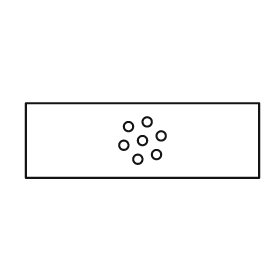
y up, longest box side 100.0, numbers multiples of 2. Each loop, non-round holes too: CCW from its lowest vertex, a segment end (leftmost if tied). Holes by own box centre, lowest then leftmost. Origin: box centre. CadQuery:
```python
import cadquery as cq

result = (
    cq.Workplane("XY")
    .moveTo(-50.0, -16.0)
    .lineTo(50.0, -16.0)
    .lineTo(50.0, 16.0)
    .lineTo(-50.0, 16.0)
    .close()
    .moveTo(-2.0, -8.0)
    .circle(2.0)
    .moveTo(6.0, -6.0)
    .circle(2.0)
    .moveTo(-8.0, -2.0)
    .circle(2.0)
    .moveTo(0.0, 0.0)
    .circle(2.0)
    .moveTo(8.0, 2.0)
    .circle(2.0)
    .moveTo(-6.0, 6.0)
    .circle(2.0)
    .moveTo(2.0, 8.0)
    .circle(2.0)
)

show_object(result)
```